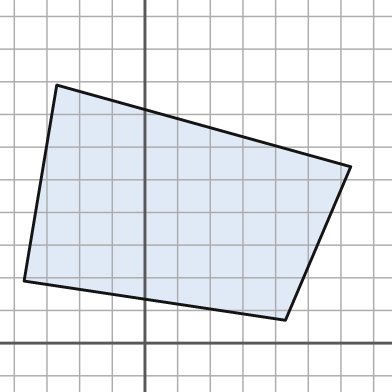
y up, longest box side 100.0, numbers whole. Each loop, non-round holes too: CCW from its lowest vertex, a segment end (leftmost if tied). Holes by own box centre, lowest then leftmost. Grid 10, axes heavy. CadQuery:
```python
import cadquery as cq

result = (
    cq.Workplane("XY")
    .moveTo(43.0, 7.0)
    .lineTo(63.0, 54.0)
    .lineTo(-27.0, 79.0)
    .lineTo(-37.0, 19.0)
    .close()
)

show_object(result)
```